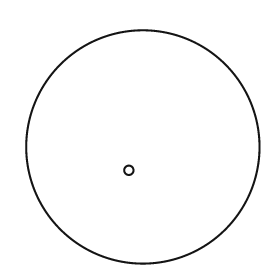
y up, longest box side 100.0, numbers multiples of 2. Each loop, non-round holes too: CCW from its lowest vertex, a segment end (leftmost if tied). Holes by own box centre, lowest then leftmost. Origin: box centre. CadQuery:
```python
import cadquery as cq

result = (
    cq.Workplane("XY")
    .moveTo(0.0, 0.0)
    .circle(50.0)
    .moveTo(-6.0, -10.0)
    .circle(2.0)
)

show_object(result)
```